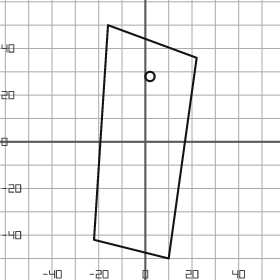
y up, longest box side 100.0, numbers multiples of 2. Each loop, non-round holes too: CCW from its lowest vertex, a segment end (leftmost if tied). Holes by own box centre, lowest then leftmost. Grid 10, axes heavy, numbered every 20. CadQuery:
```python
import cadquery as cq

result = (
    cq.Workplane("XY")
    .moveTo(10.0, -50.0)
    .lineTo(22.0, 36.0)
    .lineTo(-16.0, 50.0)
    .lineTo(-22.0, -42.0)
    .close()
    .moveTo(2.0, 28.0)
    .circle(2.0)
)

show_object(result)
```